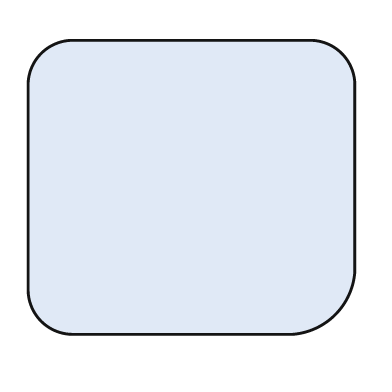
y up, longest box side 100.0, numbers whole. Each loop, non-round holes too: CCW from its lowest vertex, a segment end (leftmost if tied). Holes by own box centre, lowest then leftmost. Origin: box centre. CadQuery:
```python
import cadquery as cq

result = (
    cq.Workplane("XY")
    .moveTo(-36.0, -45.0)
    .lineTo(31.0, -45.0)
    .threePointArc((44.0, -39.0), (50.0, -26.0))
    .lineTo(50.0, 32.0)
    .threePointArc((46.0, 41.0), (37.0, 45.0))
    .lineTo(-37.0, 45.0)
    .threePointArc((-46.0, 41.0), (-50.0, 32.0))
    .lineTo(-50.0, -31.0)
    .threePointArc((-46.0, -41.0), (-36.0, -45.0))
    .close()
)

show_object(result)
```